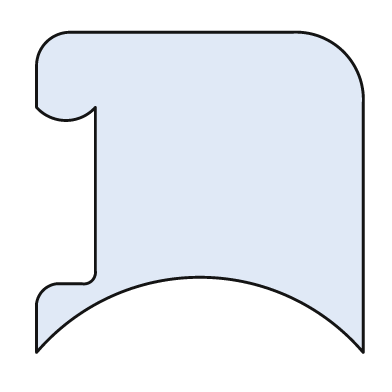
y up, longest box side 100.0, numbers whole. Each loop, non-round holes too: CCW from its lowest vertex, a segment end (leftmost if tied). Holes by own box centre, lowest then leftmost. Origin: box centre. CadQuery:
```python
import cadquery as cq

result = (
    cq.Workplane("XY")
    .moveTo(-50.0, -49.0)
    .threePointArc((0.0, -26.0), (50.0, -49.0))
    .lineTo(50.0, 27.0)
    .threePointArc((44.0, 43.0), (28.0, 49.0))
    .lineTo(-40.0, 49.0)
    .threePointArc((-47.0, 46.0), (-50.0, 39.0))
    .lineTo(-50.0, 26.0)
    .threePointArc((-41.0, 22.0), (-32.0, 26.0))
    .lineTo(-32.0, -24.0)
    .threePointArc((-33.0, -27.0), (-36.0, -28.0))
    .lineTo(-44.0, -28.0)
    .threePointArc((-48.0, -30.0), (-50.0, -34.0))
    .close()
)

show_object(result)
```